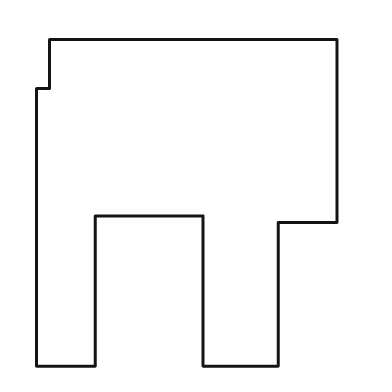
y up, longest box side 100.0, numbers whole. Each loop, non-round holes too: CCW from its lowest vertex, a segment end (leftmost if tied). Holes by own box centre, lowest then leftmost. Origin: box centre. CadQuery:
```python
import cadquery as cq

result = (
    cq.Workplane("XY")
    .moveTo(-46.0, -50.0)
    .lineTo(-28.0, -50.0)
    .lineTo(-28.0, -4.0)
    .lineTo(5.0, -4.0)
    .lineTo(5.0, -50.0)
    .lineTo(28.0, -50.0)
    .lineTo(28.0, -6.0)
    .lineTo(46.0, -6.0)
    .lineTo(46.0, 50.0)
    .lineTo(-42.0, 50.0)
    .lineTo(-42.0, 35.0)
    .lineTo(-46.0, 35.0)
    .close()
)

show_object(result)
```